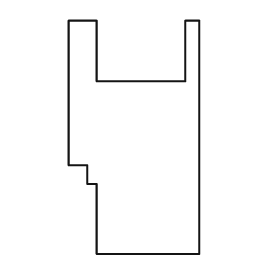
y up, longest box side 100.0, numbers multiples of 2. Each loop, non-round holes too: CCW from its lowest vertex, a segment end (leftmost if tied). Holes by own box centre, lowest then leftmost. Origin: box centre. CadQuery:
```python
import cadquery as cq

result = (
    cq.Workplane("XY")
    .moveTo(-16.0, -50.0)
    .lineTo(28.0, -50.0)
    .lineTo(28.0, 50.0)
    .lineTo(22.0, 50.0)
    .lineTo(22.0, 24.0)
    .lineTo(-16.0, 24.0)
    .lineTo(-16.0, 50.0)
    .lineTo(-28.0, 50.0)
    .lineTo(-28.0, -12.0)
    .lineTo(-20.0, -12.0)
    .lineTo(-20.0, -20.0)
    .lineTo(-16.0, -20.0)
    .close()
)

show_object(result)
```